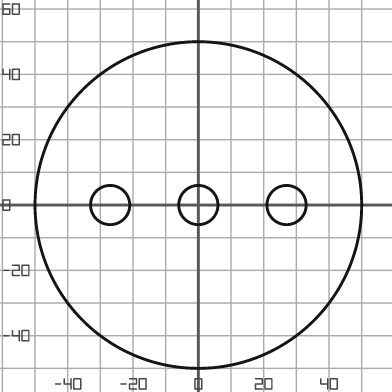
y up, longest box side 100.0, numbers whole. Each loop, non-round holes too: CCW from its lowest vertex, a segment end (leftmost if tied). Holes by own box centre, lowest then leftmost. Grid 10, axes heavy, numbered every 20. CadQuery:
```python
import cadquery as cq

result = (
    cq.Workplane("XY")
    .moveTo(0.0, 0.0)
    .circle(50.0)
    .moveTo(-27.0, 0.0)
    .circle(6.0)
    .moveTo(0.0, 0.0)
    .circle(6.0)
    .moveTo(27.0, 0.0)
    .circle(6.0)
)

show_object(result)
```